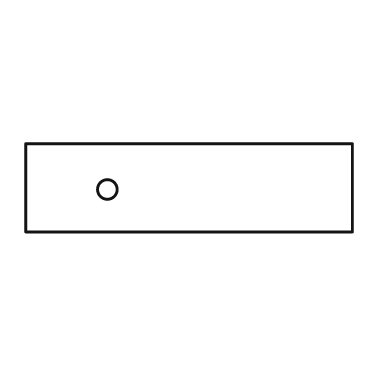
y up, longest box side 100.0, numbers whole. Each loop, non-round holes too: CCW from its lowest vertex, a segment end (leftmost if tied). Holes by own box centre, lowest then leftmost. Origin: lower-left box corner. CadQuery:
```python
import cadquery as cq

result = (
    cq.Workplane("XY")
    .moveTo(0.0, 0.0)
    .lineTo(100.0, 0.0)
    .lineTo(100.0, 27.0)
    .lineTo(0.0, 27.0)
    .close()
    .moveTo(25.0, 13.0)
    .circle(3.0)
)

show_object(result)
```